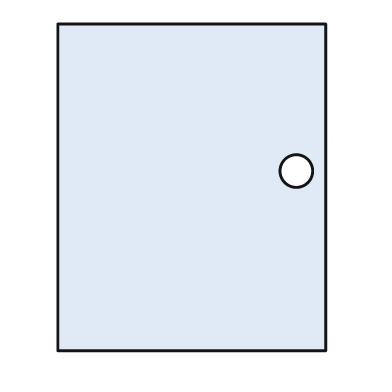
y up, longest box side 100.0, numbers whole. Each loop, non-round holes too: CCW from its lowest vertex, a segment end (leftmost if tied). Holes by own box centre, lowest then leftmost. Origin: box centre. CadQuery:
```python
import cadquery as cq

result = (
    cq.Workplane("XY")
    .moveTo(-41.0, -50.0)
    .lineTo(41.0, -50.0)
    .lineTo(41.0, 50.0)
    .lineTo(-41.0, 50.0)
    .close()
    .moveTo(32.0, 5.0)
    .circle(5.0)
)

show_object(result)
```